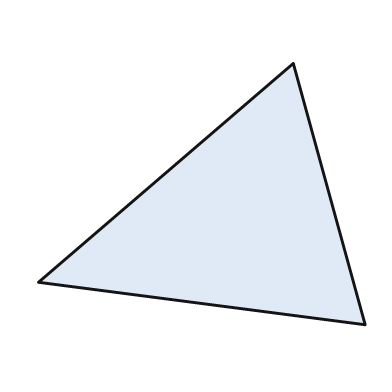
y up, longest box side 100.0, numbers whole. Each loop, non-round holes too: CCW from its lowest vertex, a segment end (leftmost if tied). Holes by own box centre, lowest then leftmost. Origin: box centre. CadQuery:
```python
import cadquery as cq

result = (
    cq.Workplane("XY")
    .moveTo(50.0, -40.0)
    .lineTo(28.0, 40.0)
    .lineTo(-50.0, -27.0)
    .close()
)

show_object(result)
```